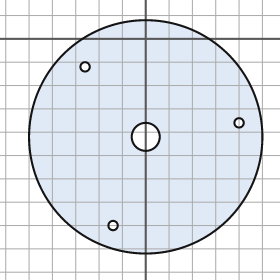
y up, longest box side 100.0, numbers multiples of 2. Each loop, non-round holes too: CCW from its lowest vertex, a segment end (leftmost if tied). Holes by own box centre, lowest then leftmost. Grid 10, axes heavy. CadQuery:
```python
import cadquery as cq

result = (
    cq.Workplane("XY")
    .moveTo(0.0, -42.0)
    .circle(50.0)
    .moveTo(-14.0, -80.0)
    .circle(2.0)
    .moveTo(0.0, -42.0)
    .circle(6.0)
    .moveTo(40.0, -36.0)
    .circle(2.0)
    .moveTo(-26.0, -12.0)
    .circle(2.0)
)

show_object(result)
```